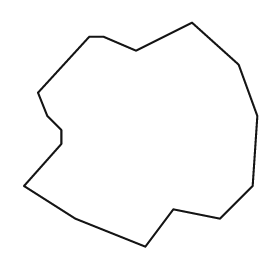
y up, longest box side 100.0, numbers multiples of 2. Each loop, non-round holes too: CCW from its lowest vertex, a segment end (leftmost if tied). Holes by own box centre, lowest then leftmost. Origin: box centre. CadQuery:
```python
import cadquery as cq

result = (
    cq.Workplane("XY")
    .moveTo(2.0, -48.0)
    .lineTo(14.0, -32.0)
    .lineTo(34.0, -36.0)
    .lineTo(48.0, -22.0)
    .lineTo(50.0, 8.0)
    .lineTo(42.0, 30.0)
    .lineTo(22.0, 48.0)
    .lineTo(-2.0, 36.0)
    .lineTo(-16.0, 42.0)
    .lineTo(-22.0, 42.0)
    .lineTo(-44.0, 18.0)
    .lineTo(-40.0, 8.0)
    .lineTo(-34.0, 2.0)
    .lineTo(-34.0, -4.0)
    .lineTo(-50.0, -22.0)
    .lineTo(-28.0, -36.0)
    .close()
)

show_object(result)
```